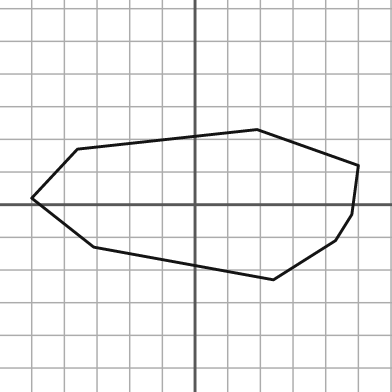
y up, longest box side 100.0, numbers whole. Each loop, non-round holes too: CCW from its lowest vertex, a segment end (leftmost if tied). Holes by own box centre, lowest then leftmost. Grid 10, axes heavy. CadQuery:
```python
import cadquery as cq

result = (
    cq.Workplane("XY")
    .moveTo(24.0, -23.0)
    .lineTo(43.0, -11.0)
    .lineTo(48.0, -3.0)
    .lineTo(50.0, 12.0)
    .lineTo(19.0, 23.0)
    .lineTo(-36.0, 17.0)
    .lineTo(-50.0, 2.0)
    .lineTo(-31.0, -13.0)
    .close()
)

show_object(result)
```